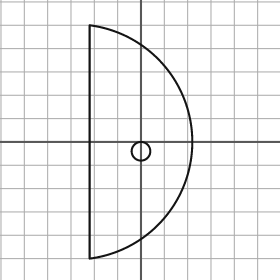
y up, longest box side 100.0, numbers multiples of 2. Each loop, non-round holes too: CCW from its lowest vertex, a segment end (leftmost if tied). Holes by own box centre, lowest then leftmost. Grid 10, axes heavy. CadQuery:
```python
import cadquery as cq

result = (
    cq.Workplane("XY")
    .moveTo(-22.0, -50.0)
    .threePointArc((22.0, 0.0), (-22.0, 50.0))
    .close()
    .moveTo(0.0, -4.0)
    .circle(4.0)
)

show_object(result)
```